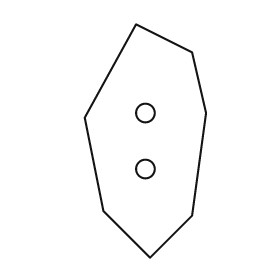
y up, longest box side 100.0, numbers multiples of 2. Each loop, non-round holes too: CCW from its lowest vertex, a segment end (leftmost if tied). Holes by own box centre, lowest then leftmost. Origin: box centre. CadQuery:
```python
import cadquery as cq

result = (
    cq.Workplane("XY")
    .moveTo(2.0, -50.0)
    .lineTo(20.0, -32.0)
    .lineTo(26.0, 12.0)
    .lineTo(20.0, 38.0)
    .lineTo(-4.0, 50.0)
    .lineTo(-26.0, 10.0)
    .lineTo(-18.0, -30.0)
    .close()
    .moveTo(0.0, -12.0)
    .circle(4.0)
    .moveTo(0.0, 12.0)
    .circle(4.0)
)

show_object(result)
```